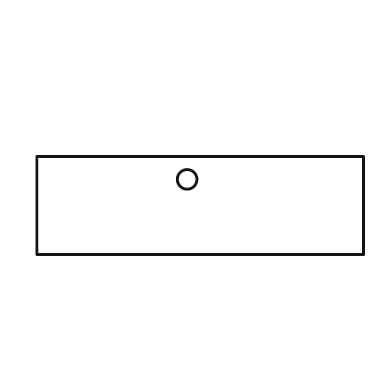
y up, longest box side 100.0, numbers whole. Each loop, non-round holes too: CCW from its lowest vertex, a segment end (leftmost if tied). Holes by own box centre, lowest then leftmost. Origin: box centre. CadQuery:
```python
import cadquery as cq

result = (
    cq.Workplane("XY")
    .moveTo(-50.0, -15.0)
    .lineTo(50.0, -15.0)
    .lineTo(50.0, 15.0)
    .lineTo(-50.0, 15.0)
    .close()
    .moveTo(-4.0, 8.0)
    .circle(3.0)
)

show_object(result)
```